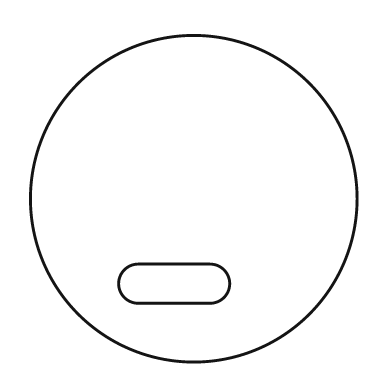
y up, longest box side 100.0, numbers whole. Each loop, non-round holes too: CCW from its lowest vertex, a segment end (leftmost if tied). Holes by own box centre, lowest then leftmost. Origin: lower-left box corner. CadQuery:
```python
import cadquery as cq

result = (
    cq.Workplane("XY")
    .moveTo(50.0, 50.0)
    .circle(50.0)
    .moveTo(33.0, 18.0)
    .lineTo(55.0, 18.0)
    .threePointArc((61.0, 24.0), (55.0, 30.0))
    .lineTo(33.0, 30.0)
    .threePointArc((27.0, 24.0), (33.0, 18.0))
    .close()
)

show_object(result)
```